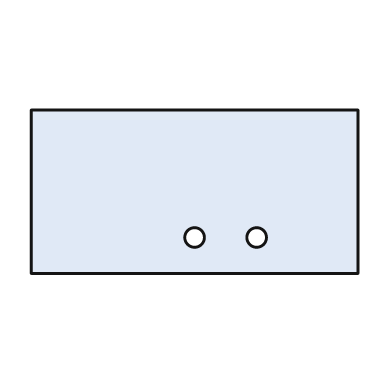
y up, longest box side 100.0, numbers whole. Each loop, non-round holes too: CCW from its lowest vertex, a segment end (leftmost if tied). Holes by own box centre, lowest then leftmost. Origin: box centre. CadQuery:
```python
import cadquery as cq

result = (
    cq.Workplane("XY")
    .moveTo(-50.0, -25.0)
    .lineTo(50.0, -25.0)
    .lineTo(50.0, 25.0)
    .lineTo(-50.0, 25.0)
    .close()
    .moveTo(0.0, -14.0)
    .circle(3.0)
    .moveTo(19.0, -14.0)
    .circle(3.0)
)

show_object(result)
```